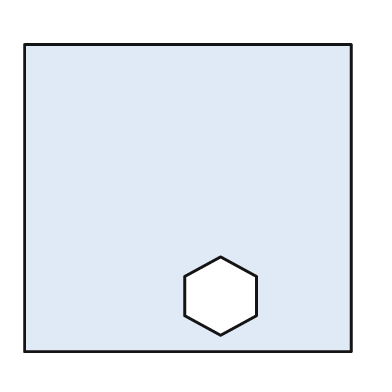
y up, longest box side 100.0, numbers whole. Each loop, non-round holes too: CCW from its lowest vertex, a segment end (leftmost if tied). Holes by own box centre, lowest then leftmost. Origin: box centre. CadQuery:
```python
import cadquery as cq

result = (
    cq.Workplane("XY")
    .moveTo(-50.0, -47.0)
    .lineTo(50.0, -47.0)
    .lineTo(50.0, 47.0)
    .lineTo(-50.0, 47.0)
    .close()
    .moveTo(10.0, -42.0)
    .lineTo(21.0, -36.0)
    .lineTo(21.0, -24.0)
    .lineTo(10.0, -18.0)
    .lineTo(-1.0, -24.0)
    .lineTo(-1.0, -36.0)
    .close()
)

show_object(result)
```